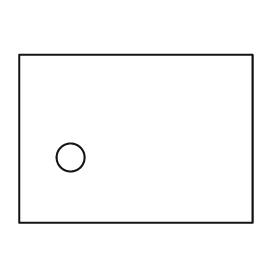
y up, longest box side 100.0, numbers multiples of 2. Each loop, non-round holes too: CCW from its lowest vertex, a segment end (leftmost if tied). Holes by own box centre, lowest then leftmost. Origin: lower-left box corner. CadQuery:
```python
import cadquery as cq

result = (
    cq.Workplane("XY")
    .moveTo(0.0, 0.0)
    .lineTo(100.0, 0.0)
    .lineTo(100.0, 72.0)
    .lineTo(0.0, 72.0)
    .close()
    .moveTo(22.0, 28.0)
    .circle(6.0)
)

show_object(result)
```